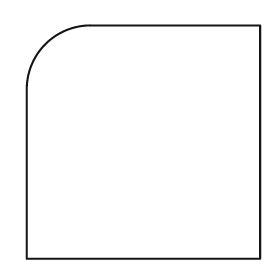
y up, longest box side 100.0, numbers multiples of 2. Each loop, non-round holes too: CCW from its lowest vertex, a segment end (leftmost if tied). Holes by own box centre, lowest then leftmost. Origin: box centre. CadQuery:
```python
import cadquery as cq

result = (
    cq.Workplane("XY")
    .moveTo(-50.0, -50.0)
    .lineTo(50.0, -50.0)
    .lineTo(50.0, 50.0)
    .lineTo(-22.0, 50.0)
    .threePointArc((-42.0, 42.0), (-50.0, 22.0))
    .close()
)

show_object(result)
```